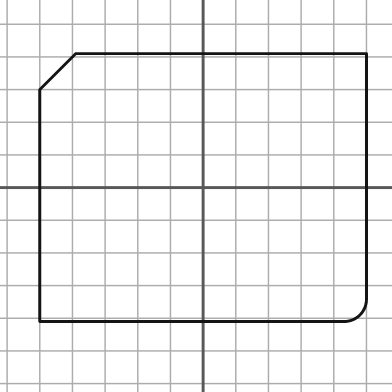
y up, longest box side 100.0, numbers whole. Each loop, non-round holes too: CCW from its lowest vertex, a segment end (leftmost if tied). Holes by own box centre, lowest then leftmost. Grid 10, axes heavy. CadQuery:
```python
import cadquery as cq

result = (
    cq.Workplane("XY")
    .moveTo(-50.0, -41.0)
    .lineTo(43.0, -41.0)
    .threePointArc((48.0, -39.0), (50.0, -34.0))
    .lineTo(50.0, 41.0)
    .lineTo(-39.0, 41.0)
    .lineTo(-50.0, 30.0)
    .close()
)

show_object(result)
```